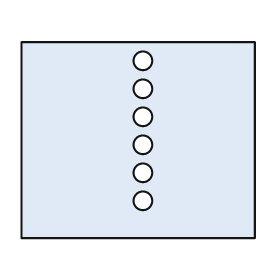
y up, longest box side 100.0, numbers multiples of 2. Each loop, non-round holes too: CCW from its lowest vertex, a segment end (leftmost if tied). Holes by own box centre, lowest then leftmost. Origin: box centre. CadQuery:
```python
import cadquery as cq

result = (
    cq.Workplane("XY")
    .moveTo(-50.0, -42.0)
    .lineTo(50.0, -42.0)
    .lineTo(50.0, 42.0)
    .lineTo(-50.0, 42.0)
    .close()
    .moveTo(2.0, -26.0)
    .circle(4.0)
    .moveTo(2.0, -14.0)
    .circle(4.0)
    .moveTo(2.0, -2.0)
    .circle(4.0)
    .moveTo(2.0, 10.0)
    .circle(4.0)
    .moveTo(2.0, 22.0)
    .circle(4.0)
    .moveTo(2.0, 34.0)
    .circle(4.0)
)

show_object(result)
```